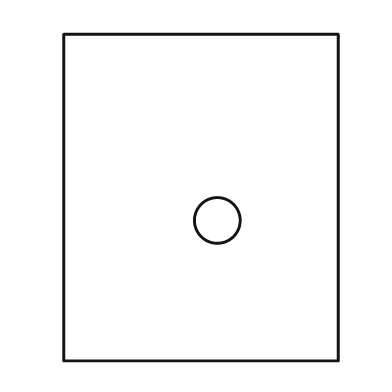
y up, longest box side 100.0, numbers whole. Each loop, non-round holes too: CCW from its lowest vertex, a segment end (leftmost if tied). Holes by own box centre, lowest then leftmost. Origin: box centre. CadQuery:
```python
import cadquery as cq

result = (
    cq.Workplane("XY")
    .moveTo(-42.0, -50.0)
    .lineTo(42.0, -50.0)
    .lineTo(42.0, 50.0)
    .lineTo(-42.0, 50.0)
    .close()
    .moveTo(5.0, -7.0)
    .circle(7.0)
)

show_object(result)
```